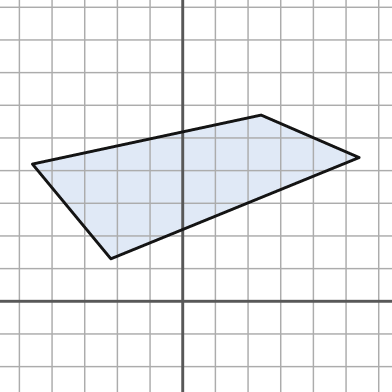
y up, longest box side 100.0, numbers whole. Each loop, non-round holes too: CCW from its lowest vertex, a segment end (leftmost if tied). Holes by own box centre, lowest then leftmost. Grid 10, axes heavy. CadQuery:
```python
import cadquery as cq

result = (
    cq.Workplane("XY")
    .moveTo(-22.0, 13.0)
    .lineTo(54.0, 44.0)
    .lineTo(24.0, 57.0)
    .lineTo(-46.0, 42.0)
    .close()
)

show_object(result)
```